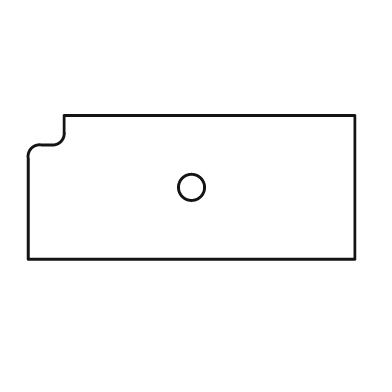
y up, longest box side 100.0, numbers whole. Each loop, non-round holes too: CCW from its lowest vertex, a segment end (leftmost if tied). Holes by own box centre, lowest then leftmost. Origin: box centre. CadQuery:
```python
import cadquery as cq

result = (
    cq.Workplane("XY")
    .moveTo(-50.0, -22.0)
    .lineTo(50.0, -22.0)
    .lineTo(50.0, 22.0)
    .lineTo(-39.0, 22.0)
    .lineTo(-39.0, 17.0)
    .threePointArc((-40.0, 14.0), (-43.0, 13.0))
    .lineTo(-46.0, 13.0)
    .threePointArc((-49.0, 12.0), (-50.0, 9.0))
    .close()
    .moveTo(0.0, 0.0)
    .circle(4.0)
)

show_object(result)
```